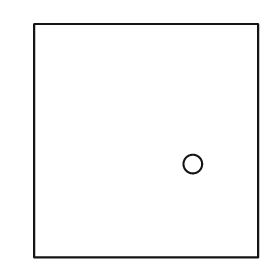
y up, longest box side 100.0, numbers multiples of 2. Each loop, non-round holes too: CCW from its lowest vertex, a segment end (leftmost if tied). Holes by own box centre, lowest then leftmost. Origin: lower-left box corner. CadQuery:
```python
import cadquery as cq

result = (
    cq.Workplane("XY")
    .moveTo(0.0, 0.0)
    .lineTo(96.0, 0.0)
    .lineTo(96.0, 100.0)
    .lineTo(0.0, 100.0)
    .close()
    .moveTo(68.0, 40.0)
    .circle(4.0)
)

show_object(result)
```